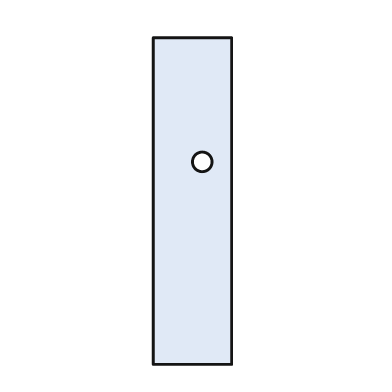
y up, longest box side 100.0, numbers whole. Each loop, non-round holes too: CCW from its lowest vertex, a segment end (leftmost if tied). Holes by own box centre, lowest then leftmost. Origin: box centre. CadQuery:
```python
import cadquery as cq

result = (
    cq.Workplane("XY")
    .moveTo(-12.0, -50.0)
    .lineTo(12.0, -50.0)
    .lineTo(12.0, 50.0)
    .lineTo(-12.0, 50.0)
    .close()
    .moveTo(3.0, 12.0)
    .circle(3.0)
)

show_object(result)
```